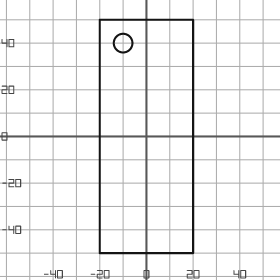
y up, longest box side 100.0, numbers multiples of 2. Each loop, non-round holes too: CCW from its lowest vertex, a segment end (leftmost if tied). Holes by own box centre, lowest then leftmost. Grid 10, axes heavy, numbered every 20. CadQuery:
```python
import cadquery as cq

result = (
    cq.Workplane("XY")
    .moveTo(-20.0, -50.0)
    .lineTo(20.0, -50.0)
    .lineTo(20.0, 50.0)
    .lineTo(-20.0, 50.0)
    .close()
    .moveTo(-10.0, 40.0)
    .circle(4.0)
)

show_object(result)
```